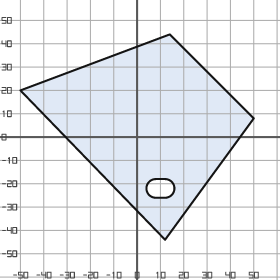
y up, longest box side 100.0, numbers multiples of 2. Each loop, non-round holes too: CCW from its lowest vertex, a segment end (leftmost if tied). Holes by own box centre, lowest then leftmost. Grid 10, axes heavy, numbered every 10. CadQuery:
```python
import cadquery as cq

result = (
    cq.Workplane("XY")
    .moveTo(12.0, -44.0)
    .lineTo(50.0, 8.0)
    .lineTo(14.0, 44.0)
    .lineTo(-50.0, 20.0)
    .close()
    .moveTo(8.0, -26.0)
    .lineTo(12.0, -26.0)
    .threePointArc((16.0, -22.0), (12.0, -18.0))
    .lineTo(8.0, -18.0)
    .threePointArc((4.0, -22.0), (8.0, -26.0))
    .close()
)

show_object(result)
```